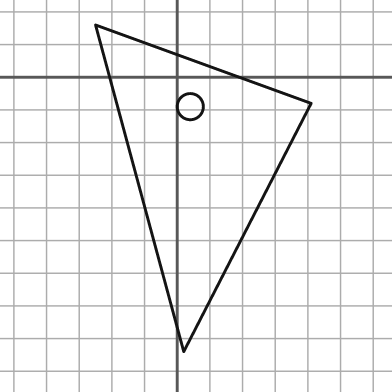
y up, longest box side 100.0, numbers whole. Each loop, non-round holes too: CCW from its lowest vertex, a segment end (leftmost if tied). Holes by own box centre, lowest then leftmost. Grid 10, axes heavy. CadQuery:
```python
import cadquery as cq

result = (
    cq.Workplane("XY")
    .moveTo(2.0, -84.0)
    .lineTo(41.0, -8.0)
    .lineTo(-25.0, 16.0)
    .close()
    .moveTo(4.0, -9.0)
    .circle(4.0)
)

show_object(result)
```